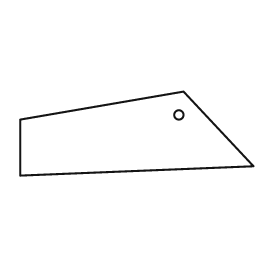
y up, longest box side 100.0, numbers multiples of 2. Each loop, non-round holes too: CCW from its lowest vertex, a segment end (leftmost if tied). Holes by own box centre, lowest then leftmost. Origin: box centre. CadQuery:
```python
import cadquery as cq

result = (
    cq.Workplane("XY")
    .moveTo(-50.0, -18.0)
    .lineTo(50.0, -14.0)
    .lineTo(20.0, 18.0)
    .lineTo(-50.0, 6.0)
    .close()
    .moveTo(18.0, 8.0)
    .circle(2.0)
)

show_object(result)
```